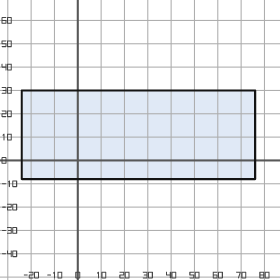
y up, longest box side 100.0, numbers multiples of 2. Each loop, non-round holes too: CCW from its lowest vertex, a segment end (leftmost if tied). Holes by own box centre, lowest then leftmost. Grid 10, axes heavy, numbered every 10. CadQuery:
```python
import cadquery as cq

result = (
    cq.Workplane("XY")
    .moveTo(-24.0, -8.0)
    .lineTo(76.0, -8.0)
    .lineTo(76.0, 30.0)
    .lineTo(-24.0, 30.0)
    .close()
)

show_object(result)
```